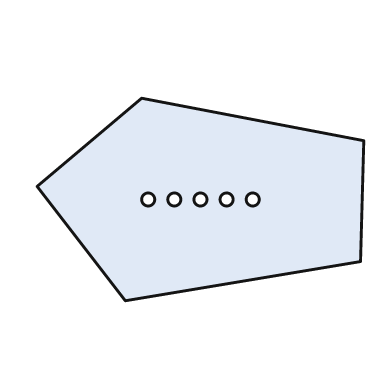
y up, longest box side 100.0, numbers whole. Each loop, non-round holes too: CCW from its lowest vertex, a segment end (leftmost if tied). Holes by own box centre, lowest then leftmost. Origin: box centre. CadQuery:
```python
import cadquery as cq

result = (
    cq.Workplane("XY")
    .moveTo(-23.0, -31.0)
    .lineTo(49.0, -19.0)
    .lineTo(50.0, 18.0)
    .lineTo(-18.0, 31.0)
    .lineTo(-50.0, 4.0)
    .close()
    .moveTo(-16.0, 0.0)
    .circle(2.0)
    .moveTo(-8.0, 0.0)
    .circle(2.0)
    .moveTo(0.0, 0.0)
    .circle(2.0)
    .moveTo(8.0, 0.0)
    .circle(2.0)
    .moveTo(16.0, 0.0)
    .circle(2.0)
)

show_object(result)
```